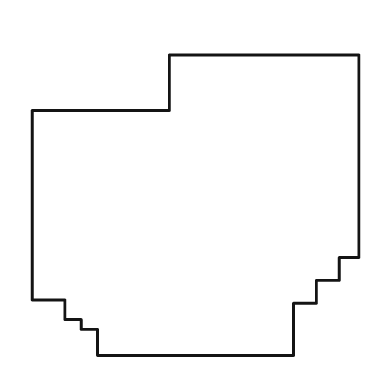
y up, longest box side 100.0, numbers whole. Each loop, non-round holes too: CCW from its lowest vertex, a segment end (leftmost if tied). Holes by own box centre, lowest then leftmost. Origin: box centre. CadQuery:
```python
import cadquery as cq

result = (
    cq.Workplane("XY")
    .moveTo(-30.0, -46.0)
    .lineTo(30.0, -46.0)
    .lineTo(30.0, -30.0)
    .lineTo(37.0, -30.0)
    .lineTo(37.0, -23.0)
    .lineTo(44.0, -23.0)
    .lineTo(44.0, -16.0)
    .lineTo(50.0, -16.0)
    .lineTo(50.0, 46.0)
    .lineTo(-8.0, 46.0)
    .lineTo(-8.0, 29.0)
    .lineTo(-50.0, 29.0)
    .lineTo(-50.0, -29.0)
    .lineTo(-40.0, -29.0)
    .lineTo(-40.0, -35.0)
    .lineTo(-35.0, -35.0)
    .lineTo(-35.0, -38.0)
    .lineTo(-30.0, -38.0)
    .close()
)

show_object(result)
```